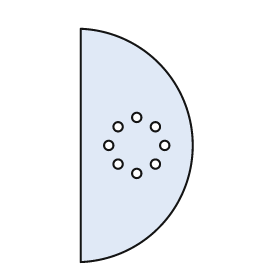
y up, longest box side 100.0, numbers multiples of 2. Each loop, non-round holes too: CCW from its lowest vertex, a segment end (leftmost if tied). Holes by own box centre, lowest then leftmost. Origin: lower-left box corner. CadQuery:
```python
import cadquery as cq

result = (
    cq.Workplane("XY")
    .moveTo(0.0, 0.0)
    .threePointArc((48.0, 50.0), (0.0, 100.0))
    .close()
    .moveTo(24.0, 38.0)
    .circle(2.0)
    .moveTo(16.0, 42.0)
    .circle(2.0)
    .moveTo(32.0, 42.0)
    .circle(2.0)
    .moveTo(12.0, 50.0)
    .circle(2.0)
    .moveTo(36.0, 50.0)
    .circle(2.0)
    .moveTo(16.0, 58.0)
    .circle(2.0)
    .moveTo(32.0, 58.0)
    .circle(2.0)
    .moveTo(24.0, 62.0)
    .circle(2.0)
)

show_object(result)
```